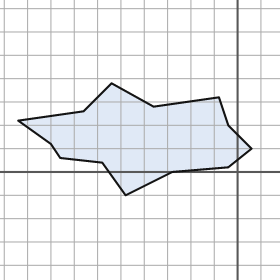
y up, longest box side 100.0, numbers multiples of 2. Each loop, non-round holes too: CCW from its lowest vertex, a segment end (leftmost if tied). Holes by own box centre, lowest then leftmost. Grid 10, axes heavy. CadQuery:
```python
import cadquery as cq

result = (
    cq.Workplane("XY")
    .moveTo(-48.0, -10.0)
    .lineTo(-28.0, 0.0)
    .lineTo(-4.0, 2.0)
    .lineTo(6.0, 10.0)
    .lineTo(-4.0, 20.0)
    .lineTo(-8.0, 32.0)
    .lineTo(-36.0, 28.0)
    .lineTo(-54.0, 38.0)
    .lineTo(-66.0, 26.0)
    .lineTo(-94.0, 22.0)
    .lineTo(-80.0, 12.0)
    .lineTo(-76.0, 6.0)
    .lineTo(-58.0, 4.0)
    .close()
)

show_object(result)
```